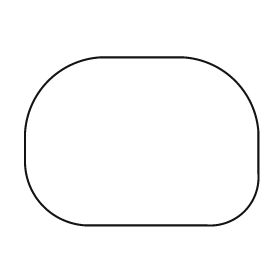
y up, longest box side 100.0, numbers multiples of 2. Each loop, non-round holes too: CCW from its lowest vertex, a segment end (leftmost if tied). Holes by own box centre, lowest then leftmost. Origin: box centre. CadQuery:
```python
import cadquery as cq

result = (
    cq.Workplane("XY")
    .moveTo(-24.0, -36.0)
    .lineTo(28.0, -36.0)
    .threePointArc((44.0, -30.0), (50.0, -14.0))
    .lineTo(50.0, 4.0)
    .threePointArc((40.0, 26.0), (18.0, 36.0))
    .lineTo(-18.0, 36.0)
    .threePointArc((-40.0, 26.0), (-50.0, 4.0))
    .lineTo(-50.0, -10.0)
    .threePointArc((-42.0, -28.0), (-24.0, -36.0))
    .close()
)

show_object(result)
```